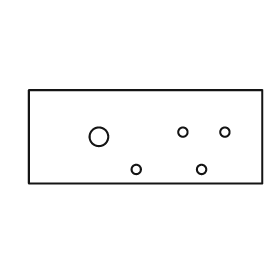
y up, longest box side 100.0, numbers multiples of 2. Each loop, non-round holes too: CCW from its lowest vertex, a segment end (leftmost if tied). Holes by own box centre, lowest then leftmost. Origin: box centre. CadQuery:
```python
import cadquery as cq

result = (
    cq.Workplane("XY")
    .moveTo(-50.0, -20.0)
    .lineTo(50.0, -20.0)
    .lineTo(50.0, 20.0)
    .lineTo(-50.0, 20.0)
    .close()
    .moveTo(-4.0, -14.0)
    .circle(2.0)
    .moveTo(24.0, -14.0)
    .circle(2.0)
    .moveTo(-20.0, 0.0)
    .circle(4.0)
    .moveTo(16.0, 2.0)
    .circle(2.0)
    .moveTo(34.0, 2.0)
    .circle(2.0)
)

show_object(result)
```